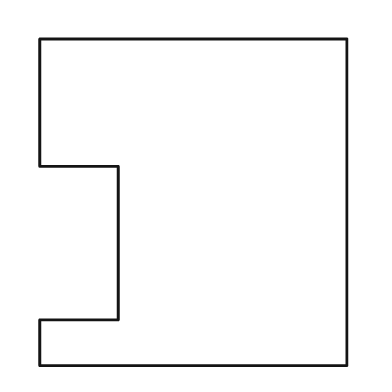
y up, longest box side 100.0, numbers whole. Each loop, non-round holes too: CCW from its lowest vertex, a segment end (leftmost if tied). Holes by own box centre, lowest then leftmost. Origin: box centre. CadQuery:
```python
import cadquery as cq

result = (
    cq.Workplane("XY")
    .moveTo(-47.0, -50.0)
    .lineTo(47.0, -50.0)
    .lineTo(47.0, 50.0)
    .lineTo(-47.0, 50.0)
    .lineTo(-47.0, 11.0)
    .lineTo(-23.0, 11.0)
    .lineTo(-23.0, -36.0)
    .lineTo(-47.0, -36.0)
    .close()
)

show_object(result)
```